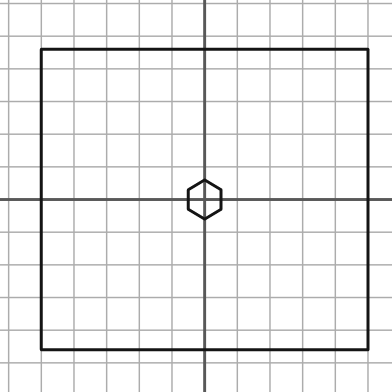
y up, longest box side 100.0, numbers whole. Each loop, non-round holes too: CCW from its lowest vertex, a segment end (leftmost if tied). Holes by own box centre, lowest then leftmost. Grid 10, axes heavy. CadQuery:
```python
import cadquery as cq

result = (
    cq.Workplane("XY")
    .moveTo(-50.0, -46.0)
    .lineTo(50.0, -46.0)
    .lineTo(50.0, 46.0)
    .lineTo(-50.0, 46.0)
    .close()
    .moveTo(0.0, -6.0)
    .lineTo(5.0, -3.0)
    .lineTo(5.0, 3.0)
    .lineTo(0.0, 6.0)
    .lineTo(-5.0, 3.0)
    .lineTo(-5.0, -3.0)
    .close()
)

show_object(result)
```